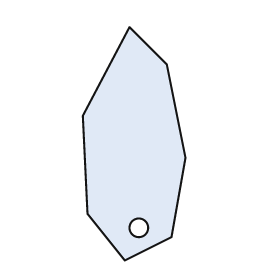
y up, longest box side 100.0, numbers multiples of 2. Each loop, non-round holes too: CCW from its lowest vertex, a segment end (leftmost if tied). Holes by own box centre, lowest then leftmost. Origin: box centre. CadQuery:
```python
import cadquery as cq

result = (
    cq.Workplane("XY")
    .moveTo(-4.0, -50.0)
    .lineTo(16.0, -40.0)
    .lineTo(22.0, -6.0)
    .lineTo(14.0, 34.0)
    .lineTo(-2.0, 50.0)
    .lineTo(-22.0, 12.0)
    .lineTo(-20.0, -30.0)
    .close()
    .moveTo(2.0, -36.0)
    .circle(4.0)
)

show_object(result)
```